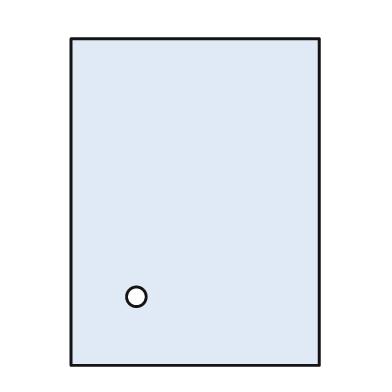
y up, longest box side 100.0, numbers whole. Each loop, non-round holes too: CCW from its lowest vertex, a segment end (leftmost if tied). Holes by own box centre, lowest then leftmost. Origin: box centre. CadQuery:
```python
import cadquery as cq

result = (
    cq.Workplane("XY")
    .moveTo(-38.0, -50.0)
    .lineTo(38.0, -50.0)
    .lineTo(38.0, 50.0)
    .lineTo(-38.0, 50.0)
    .close()
    .moveTo(-18.0, -29.0)
    .circle(3.0)
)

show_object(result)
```